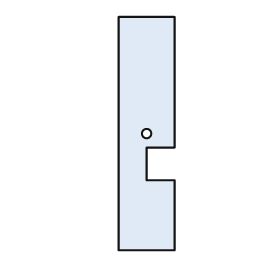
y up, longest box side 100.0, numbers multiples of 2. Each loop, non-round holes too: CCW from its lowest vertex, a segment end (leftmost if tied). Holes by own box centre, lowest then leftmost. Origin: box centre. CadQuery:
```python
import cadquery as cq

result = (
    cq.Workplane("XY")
    .moveTo(-12.0, -50.0)
    .lineTo(12.0, -50.0)
    .lineTo(12.0, -20.0)
    .lineTo(0.0, -20.0)
    .lineTo(0.0, -6.0)
    .lineTo(12.0, -6.0)
    .lineTo(12.0, 50.0)
    .lineTo(-12.0, 50.0)
    .close()
    .moveTo(0.0, 0.0)
    .circle(2.0)
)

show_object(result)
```